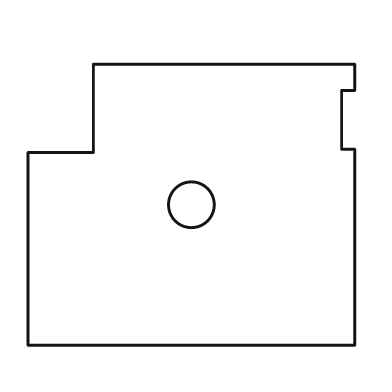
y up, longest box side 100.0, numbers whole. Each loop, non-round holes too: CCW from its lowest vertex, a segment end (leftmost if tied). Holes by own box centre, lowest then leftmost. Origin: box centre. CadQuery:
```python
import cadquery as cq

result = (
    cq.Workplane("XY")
    .moveTo(-50.0, -43.0)
    .lineTo(50.0, -43.0)
    .lineTo(50.0, 17.0)
    .lineTo(46.0, 17.0)
    .lineTo(46.0, 35.0)
    .lineTo(50.0, 35.0)
    .lineTo(50.0, 43.0)
    .lineTo(-30.0, 43.0)
    .lineTo(-30.0, 16.0)
    .lineTo(-50.0, 16.0)
    .close()
    .moveTo(0.0, 0.0)
    .circle(7.0)
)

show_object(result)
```